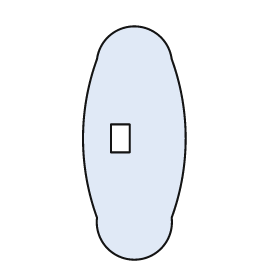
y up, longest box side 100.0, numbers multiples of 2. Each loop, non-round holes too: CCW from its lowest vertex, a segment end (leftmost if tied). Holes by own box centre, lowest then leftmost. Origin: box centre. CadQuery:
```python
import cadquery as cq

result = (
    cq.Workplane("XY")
    .moveTo(-16.0, -32.0)
    .threePointArc((0.0, -50.0), (16.0, -32.0))
    .threePointArc((22.0, 2.0), (16.0, 36.0))
    .threePointArc((0.0, 50.0), (-16.0, 36.0))
    .threePointArc((-22.0, 2.0), (-16.0, -32.0))
    .close()
    .moveTo(-10.0, -4.0)
    .lineTo(-2.0, -4.0)
    .lineTo(-2.0, 8.0)
    .lineTo(-10.0, 8.0)
    .close()
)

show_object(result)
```